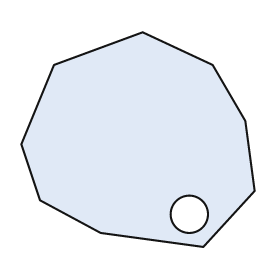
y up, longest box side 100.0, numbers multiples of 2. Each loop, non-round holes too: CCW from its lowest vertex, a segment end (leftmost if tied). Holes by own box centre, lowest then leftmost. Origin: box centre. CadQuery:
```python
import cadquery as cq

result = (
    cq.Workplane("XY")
    .moveTo(28.0, -46.0)
    .lineTo(50.0, -22.0)
    .lineTo(46.0, 8.0)
    .lineTo(32.0, 32.0)
    .lineTo(2.0, 46.0)
    .lineTo(-36.0, 32.0)
    .lineTo(-50.0, -2.0)
    .lineTo(-42.0, -26.0)
    .lineTo(-16.0, -40.0)
    .close()
    .moveTo(22.0, -32.0)
    .circle(8.0)
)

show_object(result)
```